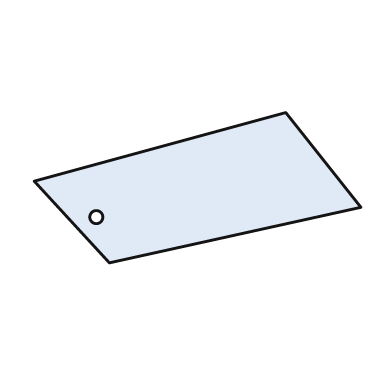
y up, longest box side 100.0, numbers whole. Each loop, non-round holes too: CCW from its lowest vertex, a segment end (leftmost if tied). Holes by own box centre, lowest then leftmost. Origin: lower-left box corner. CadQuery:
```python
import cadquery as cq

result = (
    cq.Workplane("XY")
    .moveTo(23.0, 0.0)
    .lineTo(100.0, 17.0)
    .lineTo(77.0, 46.0)
    .lineTo(0.0, 25.0)
    .close()
    .moveTo(19.0, 14.0)
    .circle(2.0)
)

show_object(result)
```